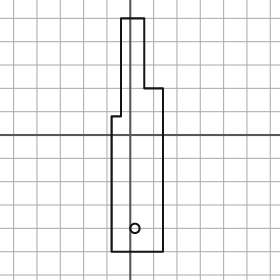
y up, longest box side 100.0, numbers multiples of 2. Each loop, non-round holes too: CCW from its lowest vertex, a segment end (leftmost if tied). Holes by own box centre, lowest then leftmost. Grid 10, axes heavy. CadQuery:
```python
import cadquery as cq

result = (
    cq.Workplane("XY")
    .moveTo(-8.0, -50.0)
    .lineTo(14.0, -50.0)
    .lineTo(14.0, 20.0)
    .lineTo(6.0, 20.0)
    .lineTo(6.0, 50.0)
    .lineTo(-4.0, 50.0)
    .lineTo(-4.0, 8.0)
    .lineTo(-8.0, 8.0)
    .close()
    .moveTo(2.0, -40.0)
    .circle(2.0)
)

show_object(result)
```